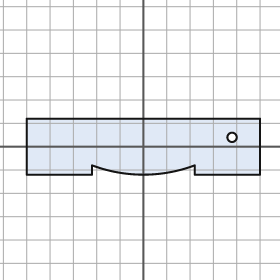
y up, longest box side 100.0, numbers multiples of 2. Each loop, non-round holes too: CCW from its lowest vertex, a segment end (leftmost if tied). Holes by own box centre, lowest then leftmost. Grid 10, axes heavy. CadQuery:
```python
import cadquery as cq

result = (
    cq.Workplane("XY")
    .moveTo(-50.0, -12.0)
    .lineTo(-22.0, -12.0)
    .lineTo(-22.0, -8.0)
    .threePointArc((0.0, -12.0), (22.0, -8.0))
    .lineTo(22.0, -12.0)
    .lineTo(50.0, -12.0)
    .lineTo(50.0, 12.0)
    .lineTo(-50.0, 12.0)
    .close()
    .moveTo(38.0, 4.0)
    .circle(2.0)
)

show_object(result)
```